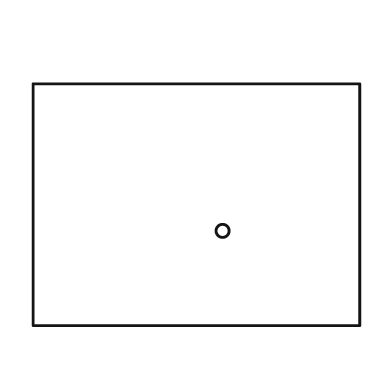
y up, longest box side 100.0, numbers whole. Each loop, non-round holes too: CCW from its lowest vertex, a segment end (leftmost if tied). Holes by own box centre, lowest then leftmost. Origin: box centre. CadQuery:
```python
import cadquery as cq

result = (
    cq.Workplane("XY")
    .moveTo(-50.0, -37.0)
    .lineTo(50.0, -37.0)
    .lineTo(50.0, 37.0)
    .lineTo(-50.0, 37.0)
    .close()
    .moveTo(8.0, -8.0)
    .circle(2.0)
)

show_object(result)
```